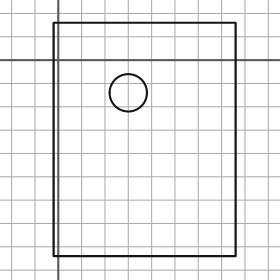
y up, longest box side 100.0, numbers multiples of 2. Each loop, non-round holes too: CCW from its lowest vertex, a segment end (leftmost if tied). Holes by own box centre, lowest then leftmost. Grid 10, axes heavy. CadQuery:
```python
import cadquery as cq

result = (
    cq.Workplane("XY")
    .moveTo(-2.0, -84.0)
    .lineTo(76.0, -84.0)
    .lineTo(76.0, 16.0)
    .lineTo(-2.0, 16.0)
    .close()
    .moveTo(30.0, -14.0)
    .circle(8.0)
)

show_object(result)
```